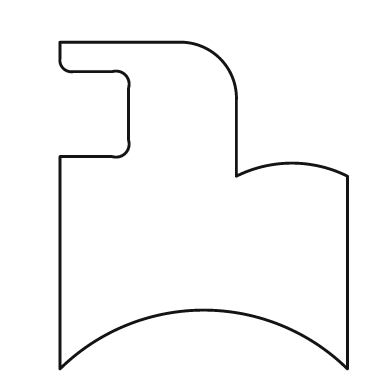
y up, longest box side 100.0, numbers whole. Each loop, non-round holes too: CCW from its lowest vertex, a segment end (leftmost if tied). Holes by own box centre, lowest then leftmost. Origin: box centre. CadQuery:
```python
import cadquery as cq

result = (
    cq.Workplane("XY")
    .moveTo(-44.0, -50.0)
    .threePointArc((0.0, -32.0), (44.0, -50.0))
    .lineTo(44.0, 9.0)
    .threePointArc((27.0, 13.0), (10.0, 9.0))
    .lineTo(10.0, 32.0)
    .threePointArc((5.0, 45.0), (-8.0, 50.0))
    .lineTo(-44.0, 50.0)
    .lineTo(-44.0, 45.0)
    .threePointArc((-43.0, 42.0), (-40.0, 41.0))
    .lineTo(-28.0, 41.0)
    .threePointArc((-24.0, 40.0), (-23.0, 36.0))
    .lineTo(-23.0, 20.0)
    .threePointArc((-24.0, 16.0), (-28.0, 15.0))
    .lineTo(-44.0, 15.0)
    .close()
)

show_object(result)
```